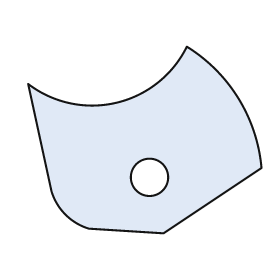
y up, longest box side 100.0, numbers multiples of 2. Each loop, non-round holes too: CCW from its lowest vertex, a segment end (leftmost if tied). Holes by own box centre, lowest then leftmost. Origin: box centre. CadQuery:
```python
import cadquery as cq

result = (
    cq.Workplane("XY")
    .moveTo(8.0, -40.0)
    .lineTo(50.0, -12.0)
    .threePointArc((40.0, 18.0), (18.0, 40.0))
    .threePointArc((-12.0, 16.0), (-50.0, 24.0))
    .lineTo(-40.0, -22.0)
    .threePointArc((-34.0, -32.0), (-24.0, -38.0))
    .close()
    .moveTo(2.0, -16.0)
    .circle(8.0)
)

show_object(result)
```